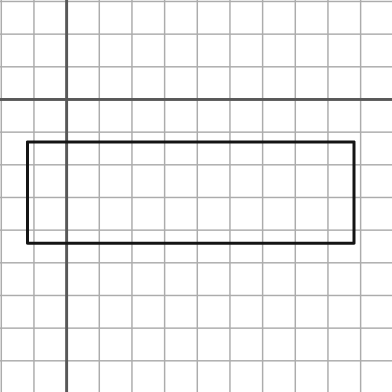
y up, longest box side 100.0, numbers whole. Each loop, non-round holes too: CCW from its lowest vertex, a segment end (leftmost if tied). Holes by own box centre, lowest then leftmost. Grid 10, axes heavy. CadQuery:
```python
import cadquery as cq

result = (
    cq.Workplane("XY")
    .moveTo(-12.0, -44.0)
    .lineTo(88.0, -44.0)
    .lineTo(88.0, -13.0)
    .lineTo(-12.0, -13.0)
    .close()
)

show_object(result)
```